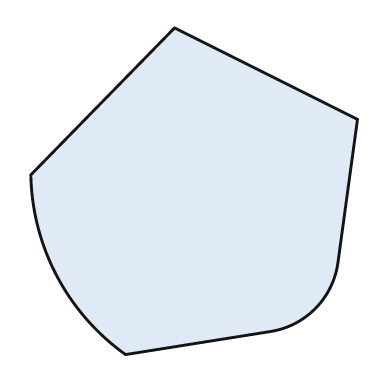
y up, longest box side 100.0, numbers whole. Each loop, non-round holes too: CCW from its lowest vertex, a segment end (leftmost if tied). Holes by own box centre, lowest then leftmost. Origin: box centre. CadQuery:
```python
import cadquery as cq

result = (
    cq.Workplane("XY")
    .moveTo(-21.0, -50.0)
    .lineTo(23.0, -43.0)
    .threePointArc((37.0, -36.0), (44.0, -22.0))
    .lineTo(50.0, 22.0)
    .lineTo(-6.0, 50.0)
    .lineTo(-50.0, 5.0)
    .threePointArc((-42.0, -26.0), (-21.0, -50.0))
    .close()
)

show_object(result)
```